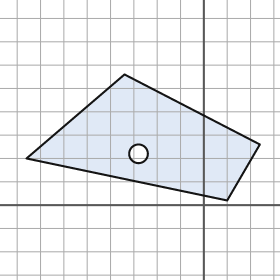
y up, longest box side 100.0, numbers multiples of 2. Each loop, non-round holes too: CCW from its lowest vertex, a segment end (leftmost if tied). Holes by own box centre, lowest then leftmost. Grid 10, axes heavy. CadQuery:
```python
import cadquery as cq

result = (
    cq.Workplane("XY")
    .moveTo(10.0, 2.0)
    .lineTo(24.0, 26.0)
    .lineTo(-34.0, 56.0)
    .lineTo(-76.0, 20.0)
    .close()
    .moveTo(-28.0, 22.0)
    .circle(4.0)
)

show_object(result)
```